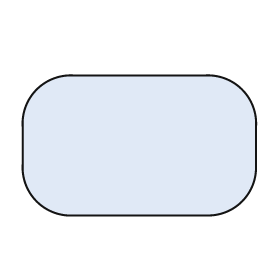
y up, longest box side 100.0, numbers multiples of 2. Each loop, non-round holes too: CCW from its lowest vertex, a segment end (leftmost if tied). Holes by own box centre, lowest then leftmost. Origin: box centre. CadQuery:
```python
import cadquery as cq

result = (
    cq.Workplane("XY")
    .moveTo(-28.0, -30.0)
    .lineTo(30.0, -30.0)
    .threePointArc((44.0, -24.0), (50.0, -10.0))
    .lineTo(50.0, 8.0)
    .threePointArc((44.0, 24.0), (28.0, 30.0))
    .lineTo(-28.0, 30.0)
    .threePointArc((-44.0, 24.0), (-50.0, 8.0))
    .lineTo(-50.0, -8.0)
    .threePointArc((-44.0, -24.0), (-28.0, -30.0))
    .close()
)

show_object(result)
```